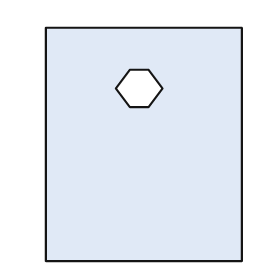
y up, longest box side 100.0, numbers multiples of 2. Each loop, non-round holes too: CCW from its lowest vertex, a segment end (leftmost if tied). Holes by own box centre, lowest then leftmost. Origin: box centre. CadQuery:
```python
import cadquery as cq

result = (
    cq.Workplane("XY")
    .moveTo(-42.0, -50.0)
    .lineTo(42.0, -50.0)
    .lineTo(42.0, 50.0)
    .lineTo(-42.0, 50.0)
    .close()
    .moveTo(-6.0, 16.0)
    .lineTo(2.0, 16.0)
    .lineTo(8.0, 24.0)
    .lineTo(2.0, 32.0)
    .lineTo(-6.0, 32.0)
    .lineTo(-12.0, 24.0)
    .close()
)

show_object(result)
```